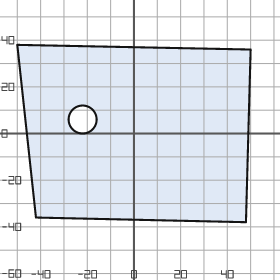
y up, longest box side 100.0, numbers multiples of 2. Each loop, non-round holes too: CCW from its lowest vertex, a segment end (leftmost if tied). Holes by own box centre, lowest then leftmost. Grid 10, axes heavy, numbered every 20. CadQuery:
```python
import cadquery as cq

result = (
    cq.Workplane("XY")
    .moveTo(48.0, -38.0)
    .lineTo(50.0, 36.0)
    .lineTo(-50.0, 38.0)
    .lineTo(-42.0, -36.0)
    .close()
    .moveTo(-22.0, 6.0)
    .circle(6.0)
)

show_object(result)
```